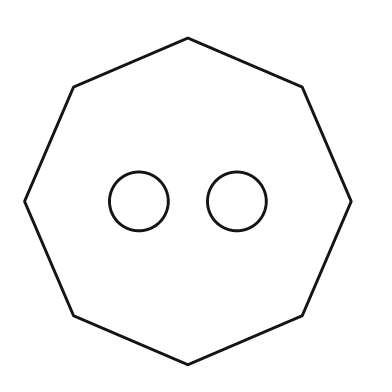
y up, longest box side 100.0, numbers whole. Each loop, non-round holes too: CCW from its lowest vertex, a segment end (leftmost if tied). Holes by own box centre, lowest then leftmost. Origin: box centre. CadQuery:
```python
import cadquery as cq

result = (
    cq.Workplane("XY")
    .moveTo(0.0, -50.0)
    .lineTo(35.0, -35.0)
    .lineTo(50.0, 0.0)
    .lineTo(35.0, 35.0)
    .lineTo(0.0, 50.0)
    .lineTo(-35.0, 35.0)
    .lineTo(-50.0, 0.0)
    .lineTo(-35.0, -35.0)
    .close()
    .moveTo(-15.0, 0.0)
    .circle(9.0)
    .moveTo(15.0, 0.0)
    .circle(9.0)
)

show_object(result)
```